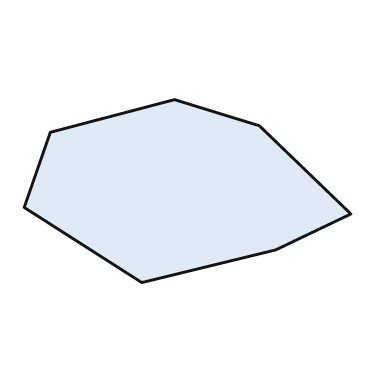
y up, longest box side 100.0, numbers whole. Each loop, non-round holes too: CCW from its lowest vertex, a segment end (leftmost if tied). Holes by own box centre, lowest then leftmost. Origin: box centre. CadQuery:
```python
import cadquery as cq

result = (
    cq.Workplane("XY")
    .moveTo(-14.0, -28.0)
    .lineTo(27.0, -18.0)
    .lineTo(50.0, -7.0)
    .lineTo(22.0, 20.0)
    .lineTo(-4.0, 28.0)
    .lineTo(-42.0, 18.0)
    .lineTo(-50.0, -5.0)
    .close()
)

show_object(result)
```